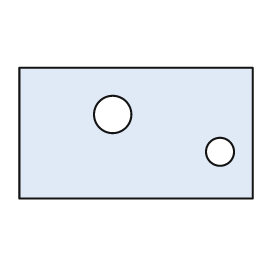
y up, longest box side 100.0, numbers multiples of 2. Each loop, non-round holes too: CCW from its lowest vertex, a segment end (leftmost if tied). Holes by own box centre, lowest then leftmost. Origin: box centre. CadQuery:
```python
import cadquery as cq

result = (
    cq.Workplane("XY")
    .moveTo(-50.0, -28.0)
    .lineTo(50.0, -28.0)
    .lineTo(50.0, 28.0)
    .lineTo(-50.0, 28.0)
    .close()
    .moveTo(36.0, -8.0)
    .circle(6.0)
    .moveTo(-10.0, 8.0)
    .circle(8.0)
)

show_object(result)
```